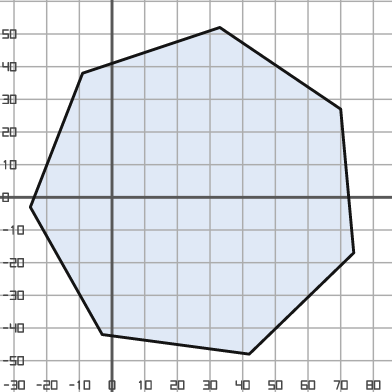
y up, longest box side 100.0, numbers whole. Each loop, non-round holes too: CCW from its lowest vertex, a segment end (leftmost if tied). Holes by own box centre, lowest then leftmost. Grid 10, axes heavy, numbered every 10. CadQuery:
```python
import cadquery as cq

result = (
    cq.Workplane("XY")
    .moveTo(42.0, -48.0)
    .lineTo(74.0, -17.0)
    .lineTo(70.0, 27.0)
    .lineTo(33.0, 52.0)
    .lineTo(-9.0, 38.0)
    .lineTo(-25.0, -3.0)
    .lineTo(-3.0, -42.0)
    .close()
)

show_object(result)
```